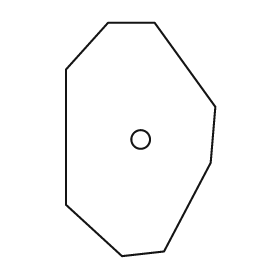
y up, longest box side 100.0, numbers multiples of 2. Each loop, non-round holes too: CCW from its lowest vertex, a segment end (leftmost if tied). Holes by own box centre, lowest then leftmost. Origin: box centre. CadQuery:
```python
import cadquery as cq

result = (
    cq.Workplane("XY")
    .moveTo(-8.0, -50.0)
    .lineTo(10.0, -48.0)
    .lineTo(30.0, -10.0)
    .lineTo(32.0, 14.0)
    .lineTo(6.0, 50.0)
    .lineTo(-14.0, 50.0)
    .lineTo(-32.0, 30.0)
    .lineTo(-32.0, -28.0)
    .close()
    .moveTo(0.0, 0.0)
    .circle(4.0)
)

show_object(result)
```